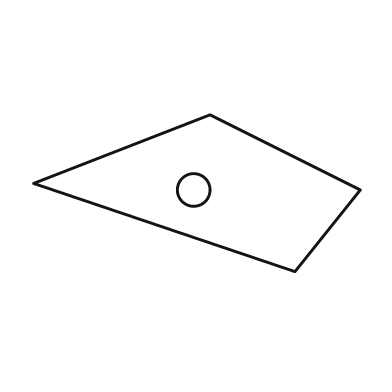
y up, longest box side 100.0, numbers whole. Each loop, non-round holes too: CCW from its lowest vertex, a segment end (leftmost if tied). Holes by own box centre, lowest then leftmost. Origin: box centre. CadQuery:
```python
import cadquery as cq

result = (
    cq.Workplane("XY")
    .moveTo(30.0, -24.0)
    .lineTo(50.0, 1.0)
    .lineTo(4.0, 24.0)
    .lineTo(-50.0, 3.0)
    .close()
    .moveTo(-1.0, 1.0)
    .circle(5.0)
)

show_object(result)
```